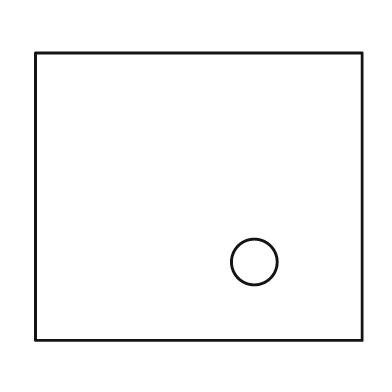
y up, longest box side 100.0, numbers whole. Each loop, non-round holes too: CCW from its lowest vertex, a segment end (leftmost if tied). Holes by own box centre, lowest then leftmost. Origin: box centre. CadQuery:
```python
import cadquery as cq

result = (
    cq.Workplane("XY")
    .moveTo(-50.0, -44.0)
    .lineTo(50.0, -44.0)
    .lineTo(50.0, 44.0)
    .lineTo(-50.0, 44.0)
    .close()
    .moveTo(17.0, -20.0)
    .circle(7.0)
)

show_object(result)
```